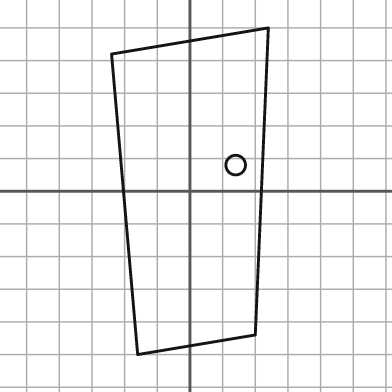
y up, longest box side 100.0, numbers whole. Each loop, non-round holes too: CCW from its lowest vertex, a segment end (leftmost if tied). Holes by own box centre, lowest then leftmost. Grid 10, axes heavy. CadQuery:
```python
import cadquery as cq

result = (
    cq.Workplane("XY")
    .moveTo(-16.0, -50.0)
    .lineTo(20.0, -44.0)
    .lineTo(24.0, 50.0)
    .lineTo(-24.0, 42.0)
    .close()
    .moveTo(14.0, 8.0)
    .circle(3.0)
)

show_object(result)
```